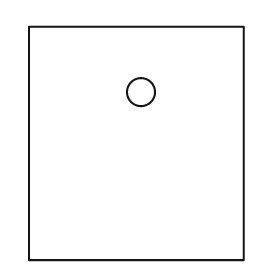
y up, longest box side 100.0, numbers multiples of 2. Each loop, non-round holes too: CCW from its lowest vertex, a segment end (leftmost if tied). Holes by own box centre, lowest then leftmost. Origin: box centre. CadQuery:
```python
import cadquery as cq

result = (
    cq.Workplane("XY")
    .moveTo(-46.0, -50.0)
    .lineTo(46.0, -50.0)
    .lineTo(46.0, 50.0)
    .lineTo(-46.0, 50.0)
    .close()
    .moveTo(2.0, 22.0)
    .circle(6.0)
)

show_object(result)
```